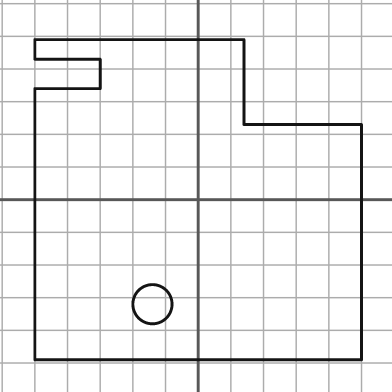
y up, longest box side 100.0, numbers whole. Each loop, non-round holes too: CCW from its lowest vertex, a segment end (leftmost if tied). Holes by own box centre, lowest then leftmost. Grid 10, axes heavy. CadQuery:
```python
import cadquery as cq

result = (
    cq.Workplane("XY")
    .moveTo(-50.0, -49.0)
    .lineTo(50.0, -49.0)
    .lineTo(50.0, 23.0)
    .lineTo(14.0, 23.0)
    .lineTo(14.0, 49.0)
    .lineTo(-50.0, 49.0)
    .lineTo(-50.0, 43.0)
    .lineTo(-30.0, 43.0)
    .lineTo(-30.0, 34.0)
    .lineTo(-50.0, 34.0)
    .close()
    .moveTo(-14.0, -32.0)
    .circle(6.0)
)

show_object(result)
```